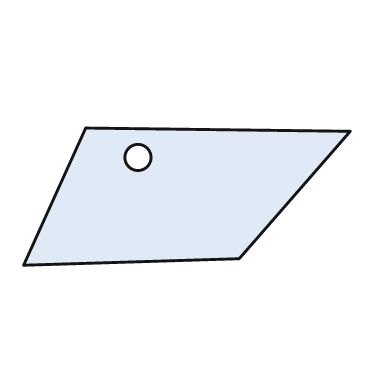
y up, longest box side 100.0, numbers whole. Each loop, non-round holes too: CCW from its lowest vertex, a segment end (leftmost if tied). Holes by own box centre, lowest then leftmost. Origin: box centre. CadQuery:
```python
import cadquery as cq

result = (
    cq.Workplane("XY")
    .moveTo(-50.0, -21.0)
    .lineTo(16.0, -19.0)
    .lineTo(50.0, 20.0)
    .lineTo(-31.0, 21.0)
    .close()
    .moveTo(-15.0, 12.0)
    .circle(4.0)
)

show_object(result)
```